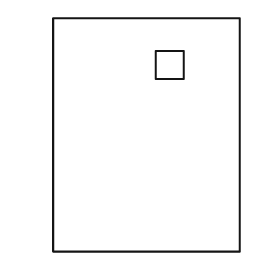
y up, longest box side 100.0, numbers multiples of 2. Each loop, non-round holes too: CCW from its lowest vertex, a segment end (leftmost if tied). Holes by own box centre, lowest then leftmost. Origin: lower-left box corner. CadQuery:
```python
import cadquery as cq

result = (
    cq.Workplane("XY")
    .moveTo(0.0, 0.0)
    .lineTo(80.0, 0.0)
    .lineTo(80.0, 100.0)
    .lineTo(0.0, 100.0)
    .close()
    .moveTo(44.0, 74.0)
    .lineTo(56.0, 74.0)
    .lineTo(56.0, 86.0)
    .lineTo(44.0, 86.0)
    .close()
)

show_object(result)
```